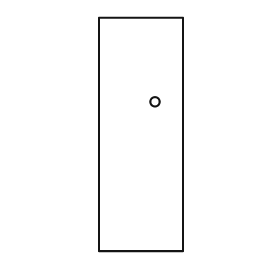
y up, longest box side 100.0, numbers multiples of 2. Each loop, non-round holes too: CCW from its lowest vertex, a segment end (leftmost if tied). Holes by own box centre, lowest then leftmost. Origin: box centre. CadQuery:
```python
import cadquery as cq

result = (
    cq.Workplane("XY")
    .moveTo(-18.0, -50.0)
    .lineTo(18.0, -50.0)
    .lineTo(18.0, 50.0)
    .lineTo(-18.0, 50.0)
    .close()
    .moveTo(6.0, 14.0)
    .circle(2.0)
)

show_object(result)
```